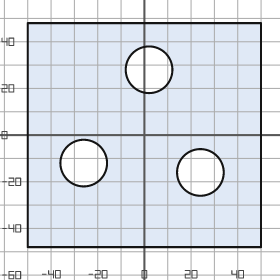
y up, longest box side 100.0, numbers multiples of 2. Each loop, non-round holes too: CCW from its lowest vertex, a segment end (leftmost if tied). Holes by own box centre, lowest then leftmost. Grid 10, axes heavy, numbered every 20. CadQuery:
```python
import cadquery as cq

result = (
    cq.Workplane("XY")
    .moveTo(-50.0, -48.0)
    .lineTo(50.0, -48.0)
    .lineTo(50.0, 48.0)
    .lineTo(-50.0, 48.0)
    .close()
    .moveTo(24.0, -16.0)
    .circle(10.0)
    .moveTo(-26.0, -12.0)
    .circle(10.0)
    .moveTo(2.0, 28.0)
    .circle(10.0)
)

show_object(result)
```